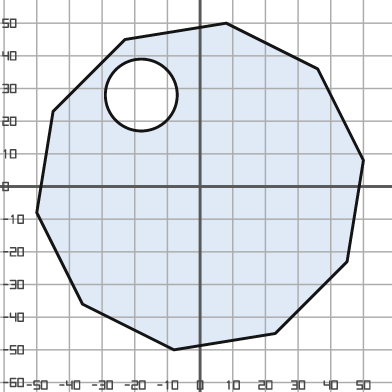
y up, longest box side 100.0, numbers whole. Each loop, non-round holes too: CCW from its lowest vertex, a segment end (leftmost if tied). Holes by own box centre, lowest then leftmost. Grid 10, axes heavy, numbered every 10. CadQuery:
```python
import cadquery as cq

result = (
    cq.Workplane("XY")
    .moveTo(-8.0, -50.0)
    .lineTo(23.0, -45.0)
    .lineTo(45.0, -23.0)
    .lineTo(50.0, 8.0)
    .lineTo(36.0, 36.0)
    .lineTo(8.0, 50.0)
    .lineTo(-23.0, 45.0)
    .lineTo(-45.0, 23.0)
    .lineTo(-50.0, -8.0)
    .lineTo(-36.0, -36.0)
    .close()
    .moveTo(-18.0, 28.0)
    .circle(11.0)
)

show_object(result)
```